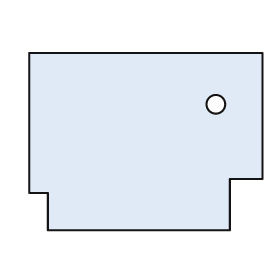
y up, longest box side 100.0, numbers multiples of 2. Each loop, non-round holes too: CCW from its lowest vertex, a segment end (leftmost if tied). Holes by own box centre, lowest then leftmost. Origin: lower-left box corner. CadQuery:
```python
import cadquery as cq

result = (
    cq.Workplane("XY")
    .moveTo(8.0, 0.0)
    .lineTo(86.0, 0.0)
    .lineTo(86.0, 22.0)
    .lineTo(100.0, 22.0)
    .lineTo(100.0, 76.0)
    .lineTo(0.0, 76.0)
    .lineTo(0.0, 16.0)
    .lineTo(8.0, 16.0)
    .close()
    .moveTo(80.0, 54.0)
    .circle(4.0)
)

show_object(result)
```